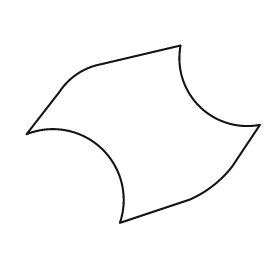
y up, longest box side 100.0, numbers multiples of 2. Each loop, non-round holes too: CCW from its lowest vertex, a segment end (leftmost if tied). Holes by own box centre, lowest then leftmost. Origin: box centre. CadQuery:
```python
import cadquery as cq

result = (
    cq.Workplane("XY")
    .moveTo(-10.0, -38.0)
    .lineTo(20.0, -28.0)
    .threePointArc((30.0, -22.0), (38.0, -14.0))
    .lineTo(50.0, 4.0)
    .threePointArc((24.0, 12.0), (16.0, 38.0))
    .lineTo(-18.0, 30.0)
    .threePointArc((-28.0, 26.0), (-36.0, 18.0))
    .lineTo(-50.0, 0.0)
    .threePointArc((-18.0, -6.0), (-10.0, -38.0))
    .close()
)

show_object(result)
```